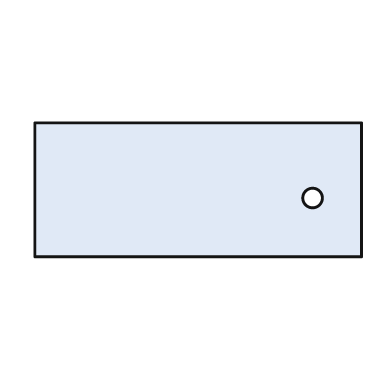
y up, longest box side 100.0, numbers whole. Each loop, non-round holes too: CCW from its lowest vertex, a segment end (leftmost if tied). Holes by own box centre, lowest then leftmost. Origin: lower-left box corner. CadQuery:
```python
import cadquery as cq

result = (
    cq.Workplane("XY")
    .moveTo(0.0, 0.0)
    .lineTo(100.0, 0.0)
    .lineTo(100.0, 41.0)
    .lineTo(0.0, 41.0)
    .close()
    .moveTo(85.0, 18.0)
    .circle(3.0)
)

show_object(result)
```